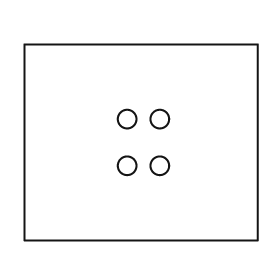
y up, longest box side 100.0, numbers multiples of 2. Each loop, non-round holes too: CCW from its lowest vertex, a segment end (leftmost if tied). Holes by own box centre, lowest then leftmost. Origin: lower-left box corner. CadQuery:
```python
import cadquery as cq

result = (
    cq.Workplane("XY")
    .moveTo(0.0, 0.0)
    .lineTo(100.0, 0.0)
    .lineTo(100.0, 84.0)
    .lineTo(0.0, 84.0)
    .close()
    .moveTo(44.0, 32.0)
    .circle(4.0)
    .moveTo(58.0, 32.0)
    .circle(4.0)
    .moveTo(44.0, 52.0)
    .circle(4.0)
    .moveTo(58.0, 52.0)
    .circle(4.0)
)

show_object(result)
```